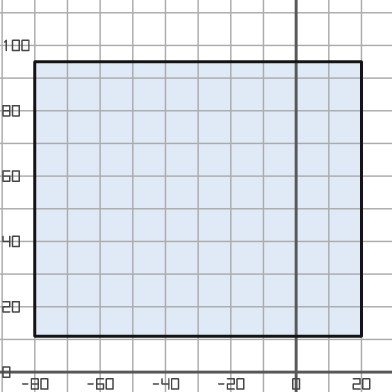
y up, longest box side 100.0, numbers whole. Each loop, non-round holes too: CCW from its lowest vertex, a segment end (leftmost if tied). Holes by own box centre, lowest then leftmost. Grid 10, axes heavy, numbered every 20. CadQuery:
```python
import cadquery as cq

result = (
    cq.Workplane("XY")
    .moveTo(-80.0, 11.0)
    .lineTo(20.0, 11.0)
    .lineTo(20.0, 95.0)
    .lineTo(-80.0, 95.0)
    .close()
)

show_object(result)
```